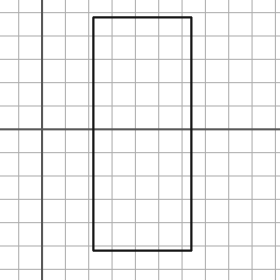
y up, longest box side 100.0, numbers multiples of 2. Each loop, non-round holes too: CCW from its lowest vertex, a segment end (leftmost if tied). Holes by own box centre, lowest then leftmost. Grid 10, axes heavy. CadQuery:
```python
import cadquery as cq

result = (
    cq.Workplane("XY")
    .moveTo(22.0, -52.0)
    .lineTo(64.0, -52.0)
    .lineTo(64.0, 48.0)
    .lineTo(22.0, 48.0)
    .close()
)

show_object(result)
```